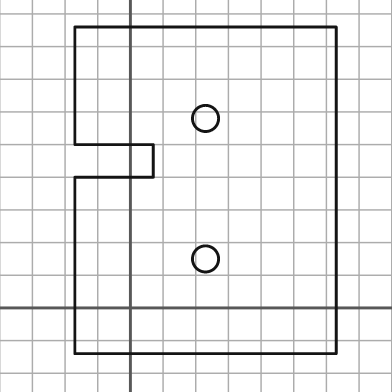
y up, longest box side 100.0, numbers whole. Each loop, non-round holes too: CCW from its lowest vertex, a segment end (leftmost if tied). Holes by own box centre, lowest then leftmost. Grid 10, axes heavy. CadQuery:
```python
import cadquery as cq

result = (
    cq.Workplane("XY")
    .moveTo(-17.0, -14.0)
    .lineTo(63.0, -14.0)
    .lineTo(63.0, 86.0)
    .lineTo(-17.0, 86.0)
    .lineTo(-17.0, 50.0)
    .lineTo(7.0, 50.0)
    .lineTo(7.0, 40.0)
    .lineTo(-17.0, 40.0)
    .close()
    .moveTo(23.0, 15.0)
    .circle(4.0)
    .moveTo(23.0, 58.0)
    .circle(4.0)
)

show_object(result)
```